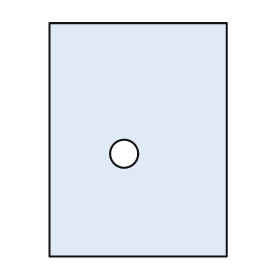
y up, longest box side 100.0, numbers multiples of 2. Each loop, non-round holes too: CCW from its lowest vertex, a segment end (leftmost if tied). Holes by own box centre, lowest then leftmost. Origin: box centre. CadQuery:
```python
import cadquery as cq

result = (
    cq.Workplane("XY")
    .moveTo(-38.0, -50.0)
    .lineTo(38.0, -50.0)
    .lineTo(38.0, 50.0)
    .lineTo(-38.0, 50.0)
    .close()
    .moveTo(-6.0, -6.0)
    .circle(6.0)
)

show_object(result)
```